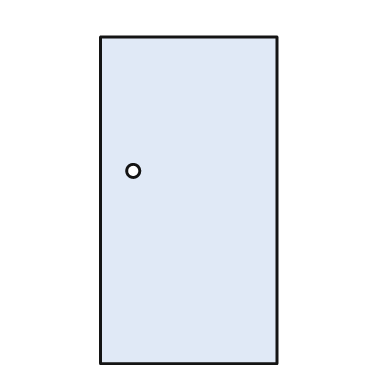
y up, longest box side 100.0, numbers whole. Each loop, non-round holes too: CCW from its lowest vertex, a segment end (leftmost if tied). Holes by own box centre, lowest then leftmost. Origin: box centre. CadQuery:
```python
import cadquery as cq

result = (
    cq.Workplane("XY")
    .moveTo(-27.0, -50.0)
    .lineTo(27.0, -50.0)
    .lineTo(27.0, 50.0)
    .lineTo(-27.0, 50.0)
    .close()
    .moveTo(-17.0, 9.0)
    .circle(2.0)
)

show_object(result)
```